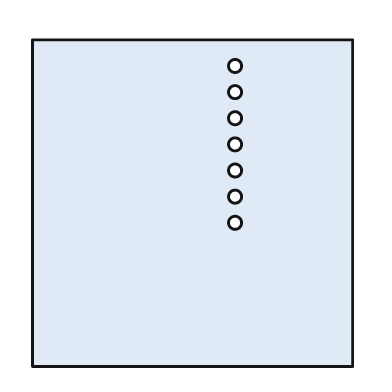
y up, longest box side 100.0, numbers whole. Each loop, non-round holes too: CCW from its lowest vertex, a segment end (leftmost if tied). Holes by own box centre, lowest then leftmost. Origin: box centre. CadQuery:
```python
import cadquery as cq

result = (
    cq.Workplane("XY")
    .moveTo(-49.0, -50.0)
    .lineTo(49.0, -50.0)
    .lineTo(49.0, 50.0)
    .lineTo(-49.0, 50.0)
    .close()
    .moveTo(13.0, -6.0)
    .circle(2.0)
    .moveTo(13.0, 2.0)
    .circle(2.0)
    .moveTo(13.0, 10.0)
    .circle(2.0)
    .moveTo(13.0, 18.0)
    .circle(2.0)
    .moveTo(13.0, 26.0)
    .circle(2.0)
    .moveTo(13.0, 34.0)
    .circle(2.0)
    .moveTo(13.0, 42.0)
    .circle(2.0)
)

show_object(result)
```